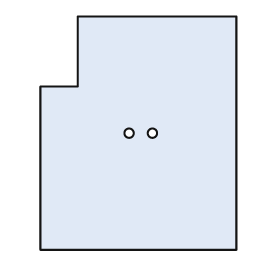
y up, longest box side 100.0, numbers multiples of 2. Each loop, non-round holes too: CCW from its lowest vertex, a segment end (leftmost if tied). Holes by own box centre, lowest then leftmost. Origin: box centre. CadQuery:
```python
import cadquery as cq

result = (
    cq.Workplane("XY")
    .moveTo(-42.0, -50.0)
    .lineTo(42.0, -50.0)
    .lineTo(42.0, 50.0)
    .lineTo(-26.0, 50.0)
    .lineTo(-26.0, 20.0)
    .lineTo(-42.0, 20.0)
    .close()
    .moveTo(-4.0, 0.0)
    .circle(2.0)
    .moveTo(6.0, 0.0)
    .circle(2.0)
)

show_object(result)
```